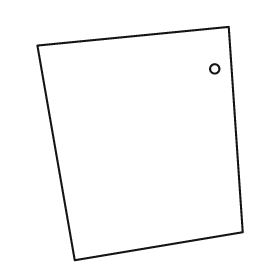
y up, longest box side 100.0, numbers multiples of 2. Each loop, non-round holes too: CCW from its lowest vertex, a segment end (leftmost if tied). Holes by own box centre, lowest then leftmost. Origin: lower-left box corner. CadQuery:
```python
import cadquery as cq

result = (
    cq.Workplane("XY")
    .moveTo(16.0, 0.0)
    .lineTo(88.0, 12.0)
    .lineTo(82.0, 100.0)
    .lineTo(0.0, 92.0)
    .close()
    .moveTo(76.0, 82.0)
    .circle(2.0)
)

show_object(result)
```